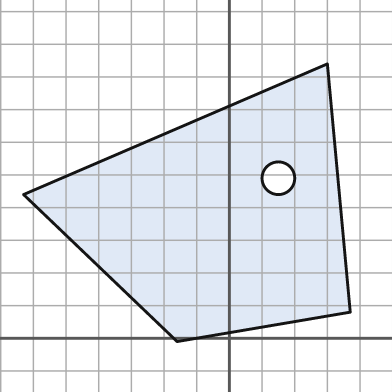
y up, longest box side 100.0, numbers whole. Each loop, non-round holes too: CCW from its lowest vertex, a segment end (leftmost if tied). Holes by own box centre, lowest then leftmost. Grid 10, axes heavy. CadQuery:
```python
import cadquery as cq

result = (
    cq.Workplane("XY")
    .moveTo(-16.0, -1.0)
    .lineTo(37.0, 8.0)
    .lineTo(30.0, 84.0)
    .lineTo(-63.0, 44.0)
    .close()
    .moveTo(15.0, 49.0)
    .circle(5.0)
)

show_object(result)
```